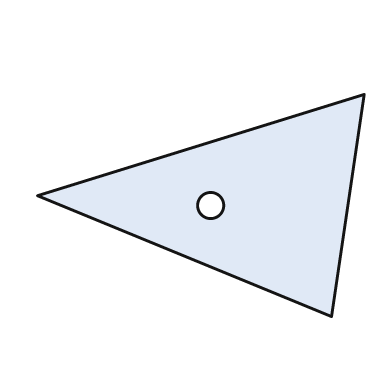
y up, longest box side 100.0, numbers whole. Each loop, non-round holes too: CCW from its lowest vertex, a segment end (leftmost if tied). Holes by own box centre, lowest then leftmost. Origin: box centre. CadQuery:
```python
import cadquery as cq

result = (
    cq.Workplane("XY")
    .moveTo(40.0, -34.0)
    .lineTo(50.0, 34.0)
    .lineTo(-50.0, 3.0)
    .close()
    .moveTo(3.0, 0.0)
    .circle(4.0)
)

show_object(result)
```